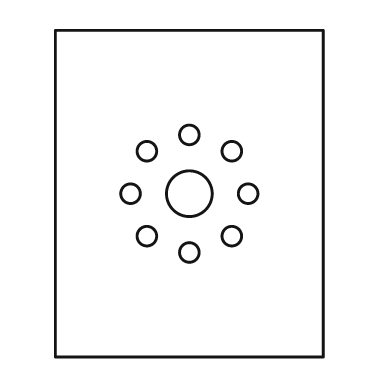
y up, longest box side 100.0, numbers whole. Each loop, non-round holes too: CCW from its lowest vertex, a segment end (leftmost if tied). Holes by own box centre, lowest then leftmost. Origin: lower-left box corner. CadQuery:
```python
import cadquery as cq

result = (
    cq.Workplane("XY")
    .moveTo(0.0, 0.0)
    .lineTo(82.0, 0.0)
    .lineTo(82.0, 100.0)
    .lineTo(0.0, 100.0)
    .close()
    .moveTo(41.0, 32.0)
    .circle(3.0)
    .moveTo(28.0, 37.0)
    .circle(3.0)
    .moveTo(54.0, 37.0)
    .circle(3.0)
    .moveTo(23.0, 50.0)
    .circle(3.0)
    .moveTo(41.0, 50.0)
    .circle(7.0)
    .moveTo(59.0, 50.0)
    .circle(3.0)
    .moveTo(28.0, 63.0)
    .circle(3.0)
    .moveTo(54.0, 63.0)
    .circle(3.0)
    .moveTo(41.0, 68.0)
    .circle(3.0)
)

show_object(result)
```